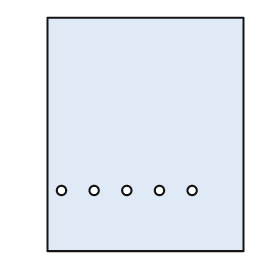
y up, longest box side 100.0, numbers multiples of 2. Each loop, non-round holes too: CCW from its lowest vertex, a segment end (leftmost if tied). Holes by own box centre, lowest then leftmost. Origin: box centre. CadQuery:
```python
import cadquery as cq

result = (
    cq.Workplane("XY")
    .moveTo(-42.0, -50.0)
    .lineTo(42.0, -50.0)
    .lineTo(42.0, 50.0)
    .lineTo(-42.0, 50.0)
    .close()
    .moveTo(-36.0, -24.0)
    .circle(2.0)
    .moveTo(-22.0, -24.0)
    .circle(2.0)
    .moveTo(-8.0, -24.0)
    .circle(2.0)
    .moveTo(6.0, -24.0)
    .circle(2.0)
    .moveTo(20.0, -24.0)
    .circle(2.0)
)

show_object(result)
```